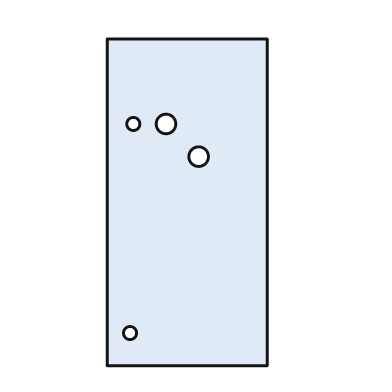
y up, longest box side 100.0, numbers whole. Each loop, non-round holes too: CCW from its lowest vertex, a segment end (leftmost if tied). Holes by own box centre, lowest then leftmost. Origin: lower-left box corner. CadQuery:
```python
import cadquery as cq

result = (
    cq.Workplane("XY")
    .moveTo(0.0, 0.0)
    .lineTo(49.0, 0.0)
    .lineTo(49.0, 100.0)
    .lineTo(0.0, 100.0)
    .close()
    .moveTo(7.0, 10.0)
    .circle(2.0)
    .moveTo(28.0, 64.0)
    .circle(3.0)
    .moveTo(8.0, 74.0)
    .circle(2.0)
    .moveTo(18.0, 74.0)
    .circle(3.0)
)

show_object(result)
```